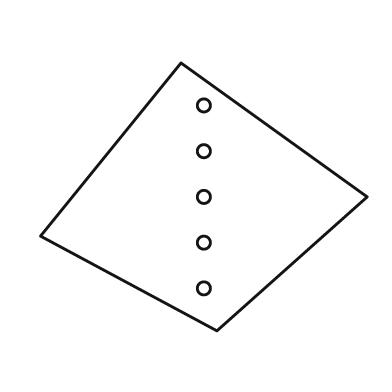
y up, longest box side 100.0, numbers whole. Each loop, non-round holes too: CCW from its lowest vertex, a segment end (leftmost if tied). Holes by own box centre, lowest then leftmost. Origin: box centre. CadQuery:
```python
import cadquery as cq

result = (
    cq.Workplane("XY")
    .moveTo(4.0, -41.0)
    .lineTo(50.0, 0.0)
    .lineTo(-7.0, 41.0)
    .lineTo(-50.0, -12.0)
    .close()
    .moveTo(0.0, -28.0)
    .circle(2.0)
    .moveTo(0.0, -14.0)
    .circle(2.0)
    .moveTo(0.0, 0.0)
    .circle(2.0)
    .moveTo(0.0, 14.0)
    .circle(2.0)
    .moveTo(0.0, 28.0)
    .circle(2.0)
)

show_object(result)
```